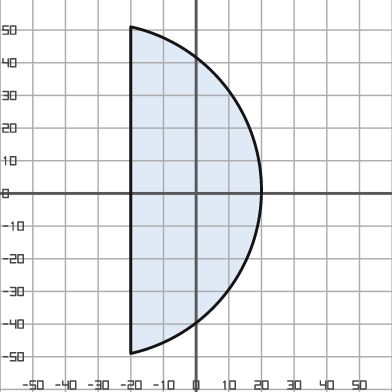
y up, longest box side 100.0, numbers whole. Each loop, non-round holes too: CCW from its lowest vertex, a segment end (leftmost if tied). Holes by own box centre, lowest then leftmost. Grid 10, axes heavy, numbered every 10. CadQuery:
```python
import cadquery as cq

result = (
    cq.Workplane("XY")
    .moveTo(-20.0, -49.0)
    .threePointArc((20.0, 1.0), (-20.0, 51.0))
    .close()
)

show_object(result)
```